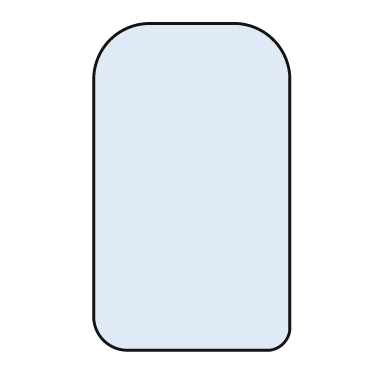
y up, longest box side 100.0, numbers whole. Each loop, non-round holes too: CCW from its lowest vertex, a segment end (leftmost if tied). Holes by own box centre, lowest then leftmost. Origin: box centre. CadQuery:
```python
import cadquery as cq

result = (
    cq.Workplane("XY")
    .moveTo(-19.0, -50.0)
    .lineTo(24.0, -50.0)
    .threePointArc((28.0, -48.0), (30.0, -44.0))
    .lineTo(30.0, 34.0)
    .threePointArc((25.0, 45.0), (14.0, 50.0))
    .lineTo(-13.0, 50.0)
    .threePointArc((-25.0, 45.0), (-30.0, 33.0))
    .lineTo(-30.0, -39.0)
    .threePointArc((-27.0, -47.0), (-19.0, -50.0))
    .close()
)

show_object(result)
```